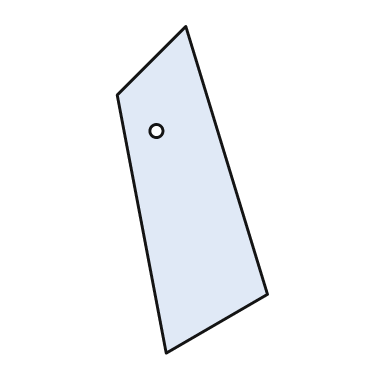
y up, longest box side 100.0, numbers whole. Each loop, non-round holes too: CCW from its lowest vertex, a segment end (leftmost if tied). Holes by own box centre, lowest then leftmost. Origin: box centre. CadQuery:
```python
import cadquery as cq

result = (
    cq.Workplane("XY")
    .moveTo(-8.0, -50.0)
    .lineTo(23.0, -32.0)
    .lineTo(-2.0, 50.0)
    .lineTo(-23.0, 29.0)
    .close()
    .moveTo(-11.0, 18.0)
    .circle(2.0)
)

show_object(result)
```